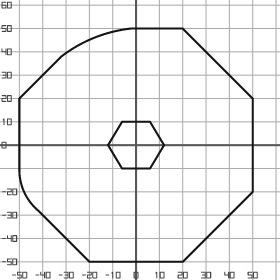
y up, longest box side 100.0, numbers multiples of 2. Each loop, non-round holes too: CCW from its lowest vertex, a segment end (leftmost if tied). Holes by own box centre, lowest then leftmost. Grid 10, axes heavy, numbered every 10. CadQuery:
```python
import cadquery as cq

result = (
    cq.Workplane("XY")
    .moveTo(-20.0, -50.0)
    .lineTo(20.0, -50.0)
    .lineTo(50.0, -20.0)
    .lineTo(50.0, 20.0)
    .lineTo(20.0, 50.0)
    .lineTo(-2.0, 50.0)
    .threePointArc((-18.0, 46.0), (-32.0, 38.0))
    .lineTo(-50.0, 20.0)
    .lineTo(-50.0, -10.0)
    .threePointArc((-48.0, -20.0), (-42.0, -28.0))
    .close()
    .moveTo(-6.0, -10.0)
    .lineTo(6.0, -10.0)
    .lineTo(12.0, 0.0)
    .lineTo(6.0, 10.0)
    .lineTo(-6.0, 10.0)
    .lineTo(-12.0, 0.0)
    .close()
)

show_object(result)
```